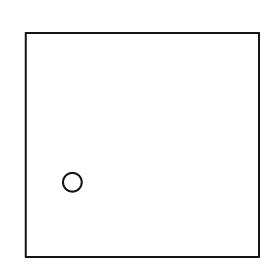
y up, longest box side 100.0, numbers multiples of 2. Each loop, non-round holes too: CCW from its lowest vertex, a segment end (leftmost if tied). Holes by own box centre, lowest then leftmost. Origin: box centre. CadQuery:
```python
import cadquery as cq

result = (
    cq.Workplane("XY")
    .moveTo(-50.0, -48.0)
    .lineTo(50.0, -48.0)
    .lineTo(50.0, 48.0)
    .lineTo(-50.0, 48.0)
    .close()
    .moveTo(-30.0, -16.0)
    .circle(4.0)
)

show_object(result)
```